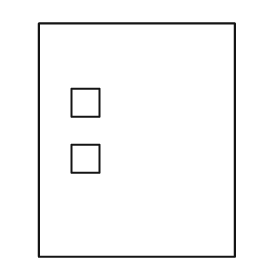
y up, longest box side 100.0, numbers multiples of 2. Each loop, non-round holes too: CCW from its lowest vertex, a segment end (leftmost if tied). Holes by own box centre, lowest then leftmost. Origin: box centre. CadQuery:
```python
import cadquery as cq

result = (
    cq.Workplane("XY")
    .moveTo(-42.0, -50.0)
    .lineTo(42.0, -50.0)
    .lineTo(42.0, 50.0)
    .lineTo(-42.0, 50.0)
    .close()
    .moveTo(-28.0, -14.0)
    .lineTo(-16.0, -14.0)
    .lineTo(-16.0, -2.0)
    .lineTo(-28.0, -2.0)
    .close()
    .moveTo(-28.0, 10.0)
    .lineTo(-16.0, 10.0)
    .lineTo(-16.0, 22.0)
    .lineTo(-28.0, 22.0)
    .close()
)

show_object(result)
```